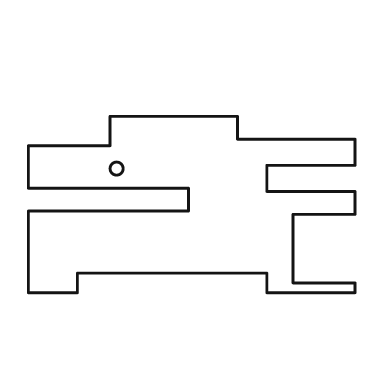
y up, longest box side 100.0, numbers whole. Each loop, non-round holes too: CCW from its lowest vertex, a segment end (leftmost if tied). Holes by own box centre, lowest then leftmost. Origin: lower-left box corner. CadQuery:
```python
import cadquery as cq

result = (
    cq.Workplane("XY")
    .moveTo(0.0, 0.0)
    .lineTo(15.0, 0.0)
    .lineTo(15.0, 6.0)
    .lineTo(73.0, 6.0)
    .lineTo(73.0, 0.0)
    .lineTo(100.0, 0.0)
    .lineTo(100.0, 3.0)
    .lineTo(81.0, 3.0)
    .lineTo(81.0, 24.0)
    .lineTo(100.0, 24.0)
    .lineTo(100.0, 31.0)
    .lineTo(73.0, 31.0)
    .lineTo(73.0, 39.0)
    .lineTo(100.0, 39.0)
    .lineTo(100.0, 47.0)
    .lineTo(64.0, 47.0)
    .lineTo(64.0, 54.0)
    .lineTo(25.0, 54.0)
    .lineTo(25.0, 45.0)
    .lineTo(0.0, 45.0)
    .lineTo(0.0, 32.0)
    .lineTo(49.0, 32.0)
    .lineTo(49.0, 25.0)
    .lineTo(0.0, 25.0)
    .close()
    .moveTo(27.0, 38.0)
    .circle(2.0)
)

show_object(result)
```